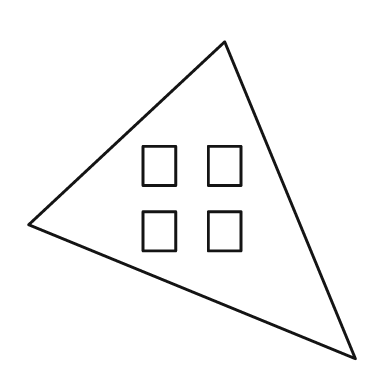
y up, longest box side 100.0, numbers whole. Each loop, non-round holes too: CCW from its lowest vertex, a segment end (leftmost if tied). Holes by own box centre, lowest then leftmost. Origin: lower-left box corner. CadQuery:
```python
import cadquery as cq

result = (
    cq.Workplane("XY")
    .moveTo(100.0, 0.0)
    .lineTo(60.0, 97.0)
    .lineTo(0.0, 41.0)
    .close()
    .moveTo(35.0, 33.0)
    .lineTo(45.0, 33.0)
    .lineTo(45.0, 45.0)
    .lineTo(35.0, 45.0)
    .close()
    .moveTo(55.0, 33.0)
    .lineTo(65.0, 33.0)
    .lineTo(65.0, 45.0)
    .lineTo(55.0, 45.0)
    .close()
    .moveTo(35.0, 53.0)
    .lineTo(45.0, 53.0)
    .lineTo(45.0, 65.0)
    .lineTo(35.0, 65.0)
    .close()
    .moveTo(55.0, 53.0)
    .lineTo(65.0, 53.0)
    .lineTo(65.0, 65.0)
    .lineTo(55.0, 65.0)
    .close()
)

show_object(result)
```